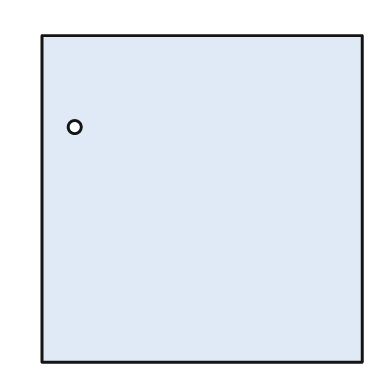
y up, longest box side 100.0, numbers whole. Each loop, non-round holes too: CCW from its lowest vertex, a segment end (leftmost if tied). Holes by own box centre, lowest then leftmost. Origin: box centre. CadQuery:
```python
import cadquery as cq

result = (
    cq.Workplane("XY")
    .moveTo(-49.0, -50.0)
    .lineTo(49.0, -50.0)
    .lineTo(49.0, 50.0)
    .lineTo(-49.0, 50.0)
    .close()
    .moveTo(-39.0, 22.0)
    .circle(2.0)
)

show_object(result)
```